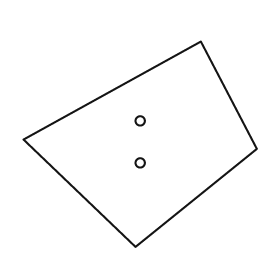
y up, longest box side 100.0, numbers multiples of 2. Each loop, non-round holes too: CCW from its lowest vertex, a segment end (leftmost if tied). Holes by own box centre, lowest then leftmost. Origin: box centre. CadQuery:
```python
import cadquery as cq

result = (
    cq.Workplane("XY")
    .moveTo(-2.0, -44.0)
    .lineTo(50.0, -2.0)
    .lineTo(26.0, 44.0)
    .lineTo(-50.0, 2.0)
    .close()
    .moveTo(0.0, -8.0)
    .circle(2.0)
    .moveTo(0.0, 10.0)
    .circle(2.0)
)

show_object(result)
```